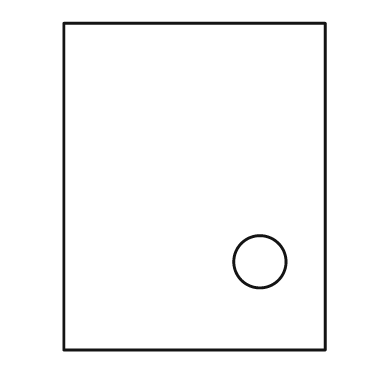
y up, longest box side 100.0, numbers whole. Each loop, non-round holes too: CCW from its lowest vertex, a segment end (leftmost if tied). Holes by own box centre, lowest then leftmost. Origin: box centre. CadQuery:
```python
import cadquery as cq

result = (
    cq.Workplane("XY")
    .moveTo(-40.0, -50.0)
    .lineTo(40.0, -50.0)
    .lineTo(40.0, 50.0)
    .lineTo(-40.0, 50.0)
    .close()
    .moveTo(20.0, -23.0)
    .circle(8.0)
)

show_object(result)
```